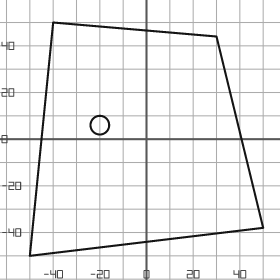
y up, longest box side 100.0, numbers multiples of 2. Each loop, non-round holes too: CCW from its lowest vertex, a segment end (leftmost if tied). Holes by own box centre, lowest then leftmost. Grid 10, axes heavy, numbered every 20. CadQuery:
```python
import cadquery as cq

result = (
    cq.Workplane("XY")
    .moveTo(-50.0, -50.0)
    .lineTo(50.0, -38.0)
    .lineTo(30.0, 44.0)
    .lineTo(-40.0, 50.0)
    .close()
    .moveTo(-20.0, 6.0)
    .circle(4.0)
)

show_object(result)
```